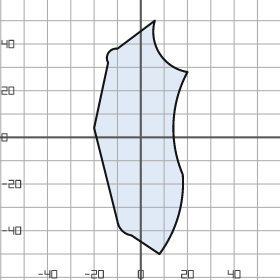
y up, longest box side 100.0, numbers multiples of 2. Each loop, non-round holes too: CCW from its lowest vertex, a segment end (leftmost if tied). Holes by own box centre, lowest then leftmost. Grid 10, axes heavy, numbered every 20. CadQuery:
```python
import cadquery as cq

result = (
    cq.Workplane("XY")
    .moveTo(8.0, -50.0)
    .threePointArc((16.0, -34.0), (18.0, -16.0))
    .threePointArc((14.0, 6.0), (20.0, 28.0))
    .threePointArc((8.0, 36.0), (6.0, 50.0))
    .lineTo(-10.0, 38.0)
    .threePointArc((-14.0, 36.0), (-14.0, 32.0))
    .lineTo(-20.0, 4.0)
    .lineTo(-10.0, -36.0)
    .threePointArc((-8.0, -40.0), (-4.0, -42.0))
    .close()
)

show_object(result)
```